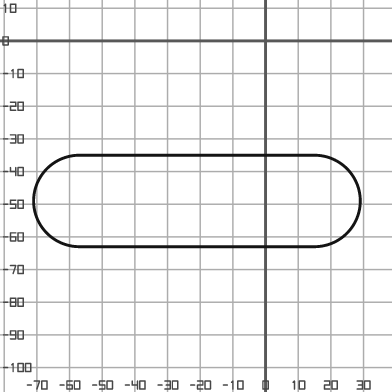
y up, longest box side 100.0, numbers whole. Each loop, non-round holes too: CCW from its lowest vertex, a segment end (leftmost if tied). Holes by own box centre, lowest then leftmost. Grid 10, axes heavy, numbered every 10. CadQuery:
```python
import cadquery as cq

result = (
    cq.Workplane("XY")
    .moveTo(-57.0, -63.0)
    .lineTo(15.0, -63.0)
    .threePointArc((29.0, -49.0), (15.0, -35.0))
    .lineTo(-57.0, -35.0)
    .threePointArc((-71.0, -49.0), (-57.0, -63.0))
    .close()
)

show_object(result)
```